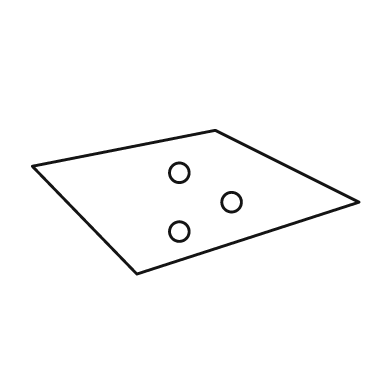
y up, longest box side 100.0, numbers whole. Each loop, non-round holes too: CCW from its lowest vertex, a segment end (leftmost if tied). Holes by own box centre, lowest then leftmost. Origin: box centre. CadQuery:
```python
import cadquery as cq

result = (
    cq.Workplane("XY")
    .moveTo(-18.0, -22.0)
    .lineTo(50.0, 0.0)
    .lineTo(6.0, 22.0)
    .lineTo(-50.0, 11.0)
    .close()
    .moveTo(-5.0, -9.0)
    .circle(3.0)
    .moveTo(11.0, 0.0)
    .circle(3.0)
    .moveTo(-5.0, 9.0)
    .circle(3.0)
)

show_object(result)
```